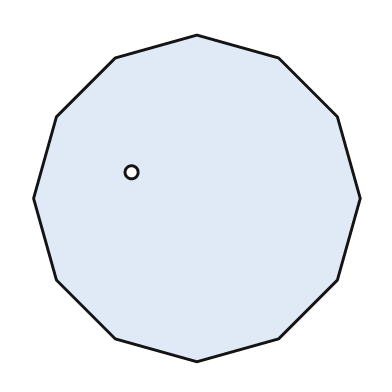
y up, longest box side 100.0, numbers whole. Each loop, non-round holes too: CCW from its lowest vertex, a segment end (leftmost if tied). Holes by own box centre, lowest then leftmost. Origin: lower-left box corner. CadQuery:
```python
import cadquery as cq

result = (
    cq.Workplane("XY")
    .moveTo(50.0, 0.0)
    .lineTo(75.0, 7.0)
    .lineTo(93.0, 25.0)
    .lineTo(100.0, 50.0)
    .lineTo(93.0, 75.0)
    .lineTo(75.0, 93.0)
    .lineTo(50.0, 100.0)
    .lineTo(25.0, 93.0)
    .lineTo(7.0, 75.0)
    .lineTo(0.0, 50.0)
    .lineTo(7.0, 25.0)
    .lineTo(25.0, 7.0)
    .close()
    .moveTo(30.0, 58.0)
    .circle(2.0)
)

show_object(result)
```